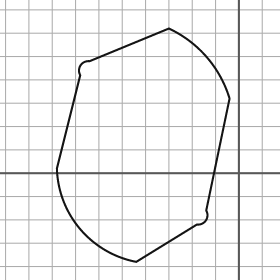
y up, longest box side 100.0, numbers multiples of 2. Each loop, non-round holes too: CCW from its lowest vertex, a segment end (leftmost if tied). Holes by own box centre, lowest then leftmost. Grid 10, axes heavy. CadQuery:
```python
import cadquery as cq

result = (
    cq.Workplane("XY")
    .moveTo(-44.0, -38.0)
    .lineTo(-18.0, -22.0)
    .threePointArc((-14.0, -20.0), (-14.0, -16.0))
    .lineTo(-4.0, 32.0)
    .threePointArc((-14.0, 50.0), (-30.0, 62.0))
    .lineTo(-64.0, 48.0)
    .threePointArc((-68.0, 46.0), (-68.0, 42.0))
    .lineTo(-78.0, 2.0)
    .threePointArc((-68.0, -24.0), (-44.0, -38.0))
    .close()
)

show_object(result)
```